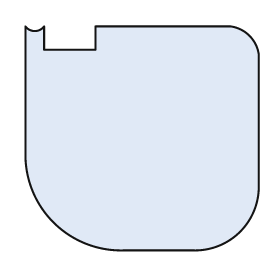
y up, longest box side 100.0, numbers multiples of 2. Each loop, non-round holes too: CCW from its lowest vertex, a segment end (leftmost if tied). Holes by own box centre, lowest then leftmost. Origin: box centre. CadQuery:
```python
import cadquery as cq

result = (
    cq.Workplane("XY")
    .moveTo(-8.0, -48.0)
    .lineTo(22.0, -48.0)
    .threePointArc((42.0, -40.0), (50.0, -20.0))
    .lineTo(50.0, 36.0)
    .threePointArc((46.0, 44.0), (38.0, 48.0))
    .lineTo(-20.0, 48.0)
    .lineTo(-20.0, 38.0)
    .lineTo(-42.0, 38.0)
    .lineTo(-42.0, 48.0)
    .threePointArc((-46.0, 46.0), (-50.0, 48.0))
    .lineTo(-50.0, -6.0)
    .threePointArc((-38.0, -36.0), (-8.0, -48.0))
    .close()
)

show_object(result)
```